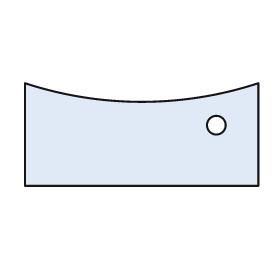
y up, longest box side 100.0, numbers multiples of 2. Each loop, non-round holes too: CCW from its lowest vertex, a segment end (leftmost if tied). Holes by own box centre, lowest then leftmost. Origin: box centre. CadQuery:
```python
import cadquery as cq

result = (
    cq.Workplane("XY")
    .moveTo(-50.0, -22.0)
    .lineTo(50.0, -22.0)
    .lineTo(50.0, 22.0)
    .threePointArc((0.0, 14.0), (-50.0, 22.0))
    .close()
    .moveTo(32.0, 4.0)
    .circle(4.0)
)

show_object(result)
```